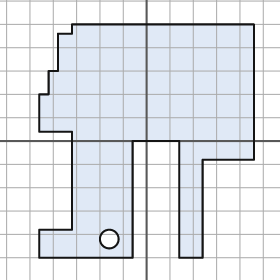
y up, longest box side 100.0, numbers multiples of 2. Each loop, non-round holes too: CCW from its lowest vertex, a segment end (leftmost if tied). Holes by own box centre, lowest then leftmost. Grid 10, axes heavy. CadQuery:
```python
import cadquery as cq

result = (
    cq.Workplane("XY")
    .moveTo(-46.0, -50.0)
    .lineTo(-6.0, -50.0)
    .lineTo(-6.0, 0.0)
    .lineTo(14.0, 0.0)
    .lineTo(14.0, -50.0)
    .lineTo(24.0, -50.0)
    .lineTo(24.0, -8.0)
    .lineTo(46.0, -8.0)
    .lineTo(46.0, 50.0)
    .lineTo(-32.0, 50.0)
    .lineTo(-32.0, 46.0)
    .lineTo(-38.0, 46.0)
    .lineTo(-38.0, 30.0)
    .lineTo(-42.0, 30.0)
    .lineTo(-42.0, 20.0)
    .lineTo(-46.0, 20.0)
    .lineTo(-46.0, 4.0)
    .lineTo(-32.0, 4.0)
    .lineTo(-32.0, -38.0)
    .lineTo(-46.0, -38.0)
    .close()
    .moveTo(-16.0, -42.0)
    .circle(4.0)
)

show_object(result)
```